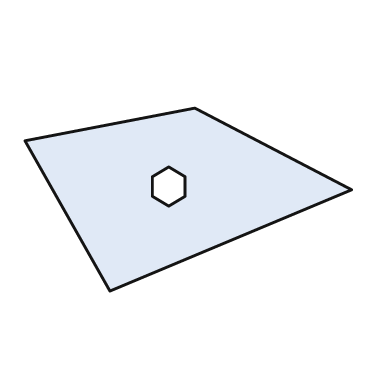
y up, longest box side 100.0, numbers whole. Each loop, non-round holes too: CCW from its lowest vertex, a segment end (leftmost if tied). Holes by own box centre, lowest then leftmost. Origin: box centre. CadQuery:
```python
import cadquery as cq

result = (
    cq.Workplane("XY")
    .moveTo(-24.0, -28.0)
    .lineTo(50.0, 3.0)
    .lineTo(2.0, 28.0)
    .lineTo(-50.0, 18.0)
    .close()
    .moveTo(-6.0, -2.0)
    .lineTo(-1.0, 1.0)
    .lineTo(-1.0, 7.0)
    .lineTo(-6.0, 10.0)
    .lineTo(-11.0, 7.0)
    .lineTo(-11.0, 1.0)
    .close()
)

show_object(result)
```